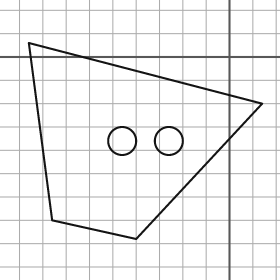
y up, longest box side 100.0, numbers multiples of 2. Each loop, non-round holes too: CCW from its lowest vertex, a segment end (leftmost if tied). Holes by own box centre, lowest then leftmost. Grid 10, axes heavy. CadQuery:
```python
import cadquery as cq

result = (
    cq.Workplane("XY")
    .moveTo(-40.0, -78.0)
    .lineTo(14.0, -20.0)
    .lineTo(-86.0, 6.0)
    .lineTo(-76.0, -70.0)
    .close()
    .moveTo(-46.0, -36.0)
    .circle(6.0)
    .moveTo(-26.0, -36.0)
    .circle(6.0)
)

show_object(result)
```